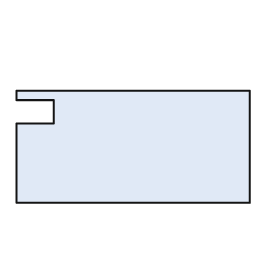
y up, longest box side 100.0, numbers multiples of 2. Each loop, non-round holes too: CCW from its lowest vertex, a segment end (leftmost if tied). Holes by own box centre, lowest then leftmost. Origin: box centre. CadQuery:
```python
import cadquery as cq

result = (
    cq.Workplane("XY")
    .moveTo(-50.0, -24.0)
    .lineTo(50.0, -24.0)
    .lineTo(50.0, 24.0)
    .lineTo(-50.0, 24.0)
    .lineTo(-50.0, 20.0)
    .lineTo(-34.0, 20.0)
    .lineTo(-34.0, 10.0)
    .lineTo(-50.0, 10.0)
    .close()
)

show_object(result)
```